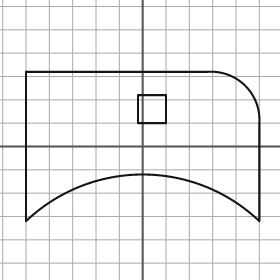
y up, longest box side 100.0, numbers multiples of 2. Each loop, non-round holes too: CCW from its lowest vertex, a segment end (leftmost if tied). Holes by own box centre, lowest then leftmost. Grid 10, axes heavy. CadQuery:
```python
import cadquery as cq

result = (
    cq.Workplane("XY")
    .moveTo(-50.0, -32.0)
    .threePointArc((0.0, -12.0), (50.0, -32.0))
    .lineTo(50.0, 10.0)
    .threePointArc((44.0, 26.0), (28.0, 32.0))
    .lineTo(-50.0, 32.0)
    .close()
    .moveTo(-2.0, 10.0)
    .lineTo(10.0, 10.0)
    .lineTo(10.0, 22.0)
    .lineTo(-2.0, 22.0)
    .close()
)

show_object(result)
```